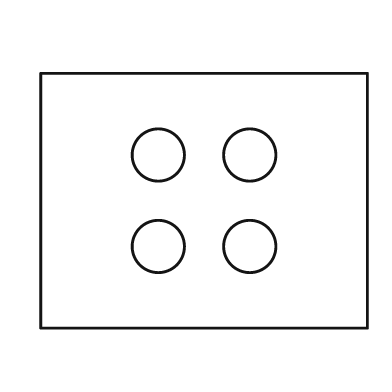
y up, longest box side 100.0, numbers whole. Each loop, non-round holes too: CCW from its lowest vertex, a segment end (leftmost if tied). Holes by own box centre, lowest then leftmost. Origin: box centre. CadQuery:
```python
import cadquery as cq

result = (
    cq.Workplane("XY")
    .moveTo(-50.0, -39.0)
    .lineTo(50.0, -39.0)
    .lineTo(50.0, 39.0)
    .lineTo(-50.0, 39.0)
    .close()
    .moveTo(-14.0, -14.0)
    .circle(8.0)
    .moveTo(14.0, -14.0)
    .circle(8.0)
    .moveTo(-14.0, 14.0)
    .circle(8.0)
    .moveTo(14.0, 14.0)
    .circle(8.0)
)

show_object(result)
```